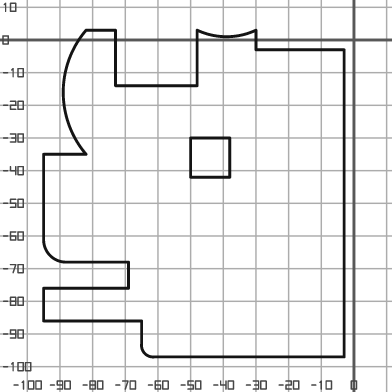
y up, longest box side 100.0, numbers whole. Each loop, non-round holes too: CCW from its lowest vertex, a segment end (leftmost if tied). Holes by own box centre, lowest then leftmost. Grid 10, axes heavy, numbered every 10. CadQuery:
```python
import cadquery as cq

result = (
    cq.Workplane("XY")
    .moveTo(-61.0, -97.0)
    .lineTo(-3.0, -97.0)
    .lineTo(-3.0, -3.0)
    .lineTo(-30.0, -3.0)
    .lineTo(-30.0, 3.0)
    .threePointArc((-39.0, 1.0), (-48.0, 3.0))
    .lineTo(-48.0, -14.0)
    .lineTo(-73.0, -14.0)
    .lineTo(-73.0, 3.0)
    .lineTo(-82.0, 3.0)
    .threePointArc((-89.0, -16.0), (-82.0, -35.0))
    .lineTo(-95.0, -35.0)
    .lineTo(-95.0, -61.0)
    .threePointArc((-93.0, -66.0), (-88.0, -68.0))
    .lineTo(-69.0, -68.0)
    .lineTo(-69.0, -76.0)
    .lineTo(-95.0, -76.0)
    .lineTo(-95.0, -86.0)
    .lineTo(-65.0, -86.0)
    .lineTo(-65.0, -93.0)
    .threePointArc((-64.0, -96.0), (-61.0, -97.0))
    .close()
    .moveTo(-50.0, -42.0)
    .lineTo(-38.0, -42.0)
    .lineTo(-38.0, -30.0)
    .lineTo(-50.0, -30.0)
    .close()
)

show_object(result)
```